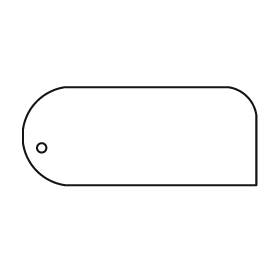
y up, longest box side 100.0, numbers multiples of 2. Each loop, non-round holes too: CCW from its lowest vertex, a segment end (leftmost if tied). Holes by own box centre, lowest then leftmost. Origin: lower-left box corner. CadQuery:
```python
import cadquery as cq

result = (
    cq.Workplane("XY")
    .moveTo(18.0, 0.0)
    .lineTo(100.0, 0.0)
    .lineTo(100.0, 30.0)
    .threePointArc((96.0, 38.0), (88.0, 42.0))
    .lineTo(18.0, 42.0)
    .threePointArc((6.0, 36.0), (0.0, 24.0))
    .lineTo(0.0, 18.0)
    .threePointArc((6.0, 6.0), (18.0, 0.0))
    .close()
    .moveTo(8.0, 16.0)
    .circle(2.0)
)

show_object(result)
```